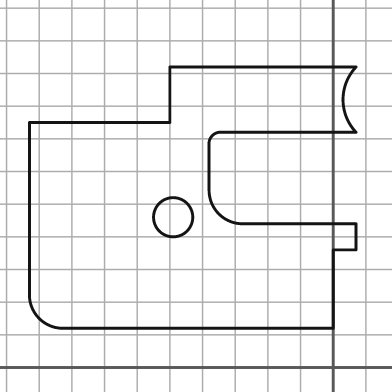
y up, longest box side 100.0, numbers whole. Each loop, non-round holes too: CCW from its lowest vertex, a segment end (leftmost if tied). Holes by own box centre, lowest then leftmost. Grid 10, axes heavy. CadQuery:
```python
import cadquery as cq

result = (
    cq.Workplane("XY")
    .moveTo(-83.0, 12.0)
    .lineTo(0.0, 12.0)
    .lineTo(0.0, 36.0)
    .lineTo(7.0, 36.0)
    .lineTo(7.0, 44.0)
    .lineTo(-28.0, 44.0)
    .threePointArc((-35.0, 47.0), (-38.0, 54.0))
    .lineTo(-38.0, 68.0)
    .threePointArc((-37.0, 71.0), (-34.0, 72.0))
    .lineTo(7.0, 72.0)
    .threePointArc((3.0, 82.0), (7.0, 92.0))
    .lineTo(-50.0, 92.0)
    .lineTo(-50.0, 75.0)
    .lineTo(-93.0, 75.0)
    .lineTo(-93.0, 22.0)
    .threePointArc((-90.0, 15.0), (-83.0, 12.0))
    .close()
    .moveTo(-49.0, 46.0)
    .circle(6.0)
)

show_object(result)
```